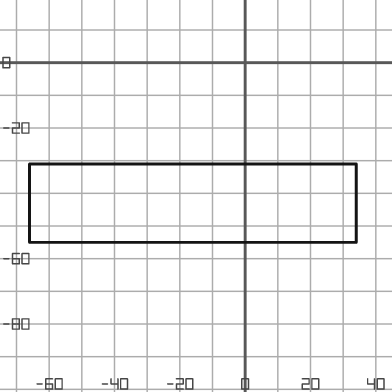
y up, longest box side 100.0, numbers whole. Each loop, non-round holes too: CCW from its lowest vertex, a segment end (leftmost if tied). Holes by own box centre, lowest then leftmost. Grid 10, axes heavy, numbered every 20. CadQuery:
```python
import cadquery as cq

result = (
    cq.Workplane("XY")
    .moveTo(-66.0, -55.0)
    .lineTo(34.0, -55.0)
    .lineTo(34.0, -31.0)
    .lineTo(-66.0, -31.0)
    .close()
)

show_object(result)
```